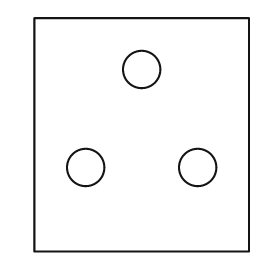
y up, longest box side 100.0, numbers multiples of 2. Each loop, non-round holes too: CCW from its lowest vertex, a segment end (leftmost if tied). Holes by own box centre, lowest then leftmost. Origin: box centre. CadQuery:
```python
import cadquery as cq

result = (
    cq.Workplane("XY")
    .moveTo(-46.0, -50.0)
    .lineTo(46.0, -50.0)
    .lineTo(46.0, 50.0)
    .lineTo(-46.0, 50.0)
    .close()
    .moveTo(-24.0, -14.0)
    .circle(8.0)
    .moveTo(24.0, -14.0)
    .circle(8.0)
    .moveTo(0.0, 28.0)
    .circle(8.0)
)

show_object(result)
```